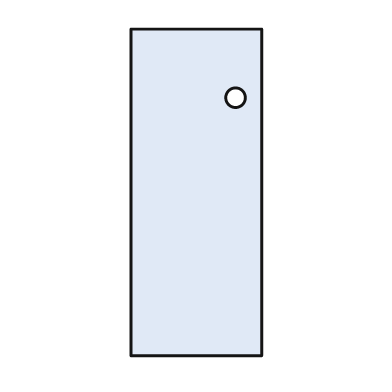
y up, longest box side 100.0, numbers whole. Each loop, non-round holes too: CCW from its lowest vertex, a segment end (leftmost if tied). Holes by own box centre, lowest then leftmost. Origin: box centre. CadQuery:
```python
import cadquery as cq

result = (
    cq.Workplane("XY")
    .moveTo(-20.0, -50.0)
    .lineTo(20.0, -50.0)
    .lineTo(20.0, 50.0)
    .lineTo(-20.0, 50.0)
    .close()
    .moveTo(12.0, 29.0)
    .circle(3.0)
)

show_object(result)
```